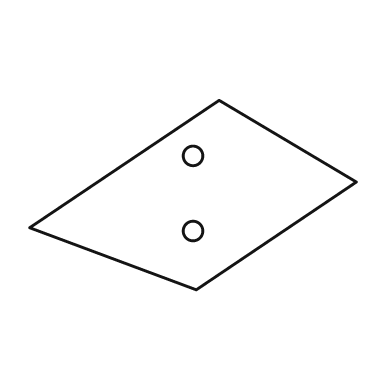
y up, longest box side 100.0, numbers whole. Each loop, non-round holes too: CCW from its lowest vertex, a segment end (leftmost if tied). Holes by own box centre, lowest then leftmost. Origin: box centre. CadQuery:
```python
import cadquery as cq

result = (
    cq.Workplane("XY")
    .moveTo(1.0, -29.0)
    .lineTo(50.0, 4.0)
    .lineTo(8.0, 29.0)
    .lineTo(-50.0, -10.0)
    .close()
    .moveTo(0.0, -11.0)
    .circle(3.0)
    .moveTo(0.0, 12.0)
    .circle(3.0)
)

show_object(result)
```